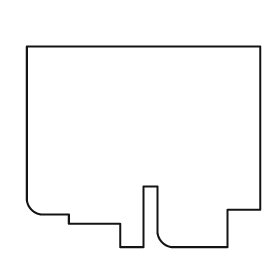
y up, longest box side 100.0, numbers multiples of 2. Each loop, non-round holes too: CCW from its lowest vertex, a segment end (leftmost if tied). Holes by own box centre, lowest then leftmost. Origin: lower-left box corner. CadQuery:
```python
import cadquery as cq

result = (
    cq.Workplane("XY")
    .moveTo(40.0, 0.0)
    .lineTo(50.0, 0.0)
    .lineTo(50.0, 26.0)
    .lineTo(56.0, 26.0)
    .lineTo(56.0, 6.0)
    .threePointArc((58.0, 2.0), (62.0, 0.0))
    .lineTo(86.0, 0.0)
    .lineTo(86.0, 16.0)
    .lineTo(100.0, 16.0)
    .lineTo(100.0, 86.0)
    .lineTo(0.0, 86.0)
    .lineTo(0.0, 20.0)
    .threePointArc((2.0, 16.0), (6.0, 14.0))
    .lineTo(18.0, 14.0)
    .lineTo(18.0, 10.0)
    .lineTo(40.0, 10.0)
    .close()
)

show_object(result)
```